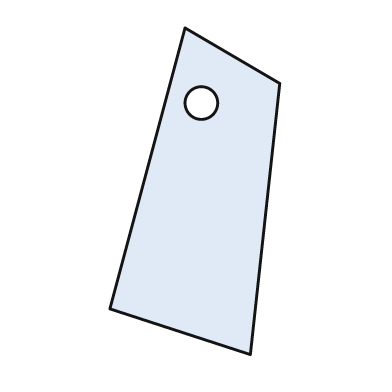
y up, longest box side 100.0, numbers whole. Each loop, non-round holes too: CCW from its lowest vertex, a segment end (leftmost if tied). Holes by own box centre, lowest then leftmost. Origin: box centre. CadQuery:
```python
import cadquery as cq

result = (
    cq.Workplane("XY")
    .moveTo(17.0, -50.0)
    .lineTo(26.0, 33.0)
    .lineTo(-3.0, 50.0)
    .lineTo(-26.0, -36.0)
    .close()
    .moveTo(2.0, 27.0)
    .circle(5.0)
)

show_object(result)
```